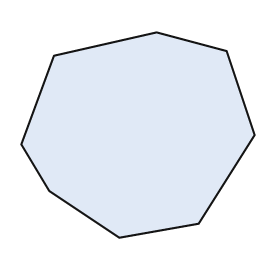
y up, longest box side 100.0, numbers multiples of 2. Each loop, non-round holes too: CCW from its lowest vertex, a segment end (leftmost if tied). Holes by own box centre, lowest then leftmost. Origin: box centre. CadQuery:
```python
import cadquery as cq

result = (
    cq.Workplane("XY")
    .moveTo(-8.0, -44.0)
    .lineTo(26.0, -38.0)
    .lineTo(50.0, 0.0)
    .lineTo(38.0, 36.0)
    .lineTo(8.0, 44.0)
    .lineTo(-36.0, 34.0)
    .lineTo(-50.0, -4.0)
    .lineTo(-38.0, -24.0)
    .close()
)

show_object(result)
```